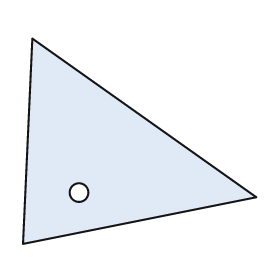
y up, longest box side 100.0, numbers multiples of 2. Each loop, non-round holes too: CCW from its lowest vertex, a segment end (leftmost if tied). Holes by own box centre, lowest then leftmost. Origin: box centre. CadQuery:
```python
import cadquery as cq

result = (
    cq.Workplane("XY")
    .moveTo(-50.0, -44.0)
    .lineTo(50.0, -24.0)
    .lineTo(-46.0, 44.0)
    .close()
    .moveTo(-26.0, -22.0)
    .circle(4.0)
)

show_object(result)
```